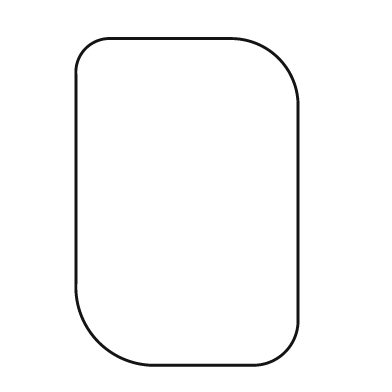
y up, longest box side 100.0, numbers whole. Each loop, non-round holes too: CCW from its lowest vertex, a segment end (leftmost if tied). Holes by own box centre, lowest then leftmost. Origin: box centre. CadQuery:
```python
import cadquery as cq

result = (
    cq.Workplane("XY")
    .moveTo(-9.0, -50.0)
    .lineTo(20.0, -50.0)
    .threePointArc((30.0, -46.0), (34.0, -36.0))
    .lineTo(34.0, 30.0)
    .threePointArc((28.0, 44.0), (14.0, 50.0))
    .lineTo(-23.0, 50.0)
    .threePointArc((-31.0, 47.0), (-34.0, 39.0))
    .lineTo(-34.0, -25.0)
    .threePointArc((-27.0, -43.0), (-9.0, -50.0))
    .close()
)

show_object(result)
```